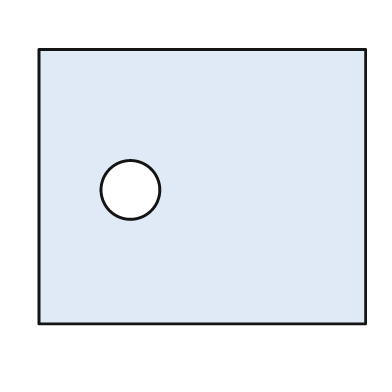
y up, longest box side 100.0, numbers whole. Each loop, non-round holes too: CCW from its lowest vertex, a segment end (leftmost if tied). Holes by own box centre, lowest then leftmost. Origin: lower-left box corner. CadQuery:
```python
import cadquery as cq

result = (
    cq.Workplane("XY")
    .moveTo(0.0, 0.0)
    .lineTo(100.0, 0.0)
    .lineTo(100.0, 84.0)
    .lineTo(0.0, 84.0)
    .close()
    .moveTo(28.0, 41.0)
    .circle(9.0)
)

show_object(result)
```